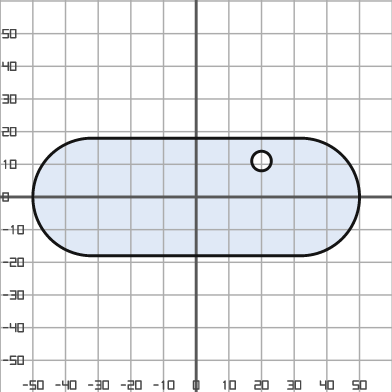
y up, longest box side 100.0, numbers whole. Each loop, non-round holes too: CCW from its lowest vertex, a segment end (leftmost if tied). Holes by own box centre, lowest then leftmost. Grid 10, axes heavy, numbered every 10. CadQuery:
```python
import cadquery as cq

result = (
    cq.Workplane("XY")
    .moveTo(-32.0, -18.0)
    .lineTo(32.0, -18.0)
    .threePointArc((50.0, 0.0), (32.0, 18.0))
    .lineTo(-32.0, 18.0)
    .threePointArc((-50.0, 0.0), (-32.0, -18.0))
    .close()
    .moveTo(20.0, 11.0)
    .circle(3.0)
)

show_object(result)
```